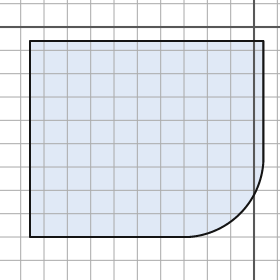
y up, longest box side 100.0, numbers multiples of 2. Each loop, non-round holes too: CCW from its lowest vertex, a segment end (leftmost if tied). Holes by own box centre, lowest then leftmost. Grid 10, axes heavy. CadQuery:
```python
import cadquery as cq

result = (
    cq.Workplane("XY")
    .moveTo(-96.0, -90.0)
    .lineTo(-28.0, -90.0)
    .threePointArc((-6.0, -80.0), (4.0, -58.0))
    .lineTo(4.0, -6.0)
    .lineTo(-96.0, -6.0)
    .close()
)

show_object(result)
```